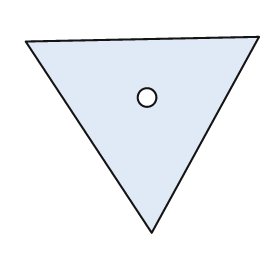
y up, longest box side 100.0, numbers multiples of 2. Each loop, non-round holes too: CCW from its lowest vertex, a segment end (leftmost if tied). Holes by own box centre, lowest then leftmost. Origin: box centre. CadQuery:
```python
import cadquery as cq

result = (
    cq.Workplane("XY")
    .moveTo(4.0, -42.0)
    .lineTo(50.0, 42.0)
    .lineTo(-50.0, 40.0)
    .close()
    .moveTo(2.0, 16.0)
    .circle(4.0)
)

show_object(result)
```